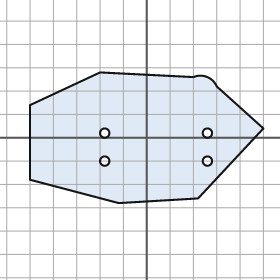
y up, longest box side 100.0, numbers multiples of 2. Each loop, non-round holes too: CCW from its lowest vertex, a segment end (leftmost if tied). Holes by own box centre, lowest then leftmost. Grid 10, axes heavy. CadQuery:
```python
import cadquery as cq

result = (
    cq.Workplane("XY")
    .moveTo(-12.0, -28.0)
    .lineTo(22.0, -26.0)
    .lineTo(50.0, 4.0)
    .lineTo(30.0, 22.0)
    .threePointArc((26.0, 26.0), (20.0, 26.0))
    .lineTo(-20.0, 28.0)
    .lineTo(-50.0, 14.0)
    .lineTo(-50.0, -18.0)
    .close()
    .moveTo(-18.0, -10.0)
    .circle(2.0)
    .moveTo(26.0, -10.0)
    .circle(2.0)
    .moveTo(-18.0, 2.0)
    .circle(2.0)
    .moveTo(26.0, 2.0)
    .circle(2.0)
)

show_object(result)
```